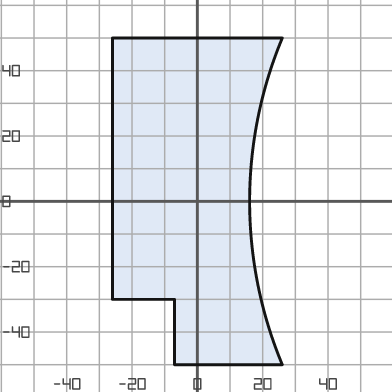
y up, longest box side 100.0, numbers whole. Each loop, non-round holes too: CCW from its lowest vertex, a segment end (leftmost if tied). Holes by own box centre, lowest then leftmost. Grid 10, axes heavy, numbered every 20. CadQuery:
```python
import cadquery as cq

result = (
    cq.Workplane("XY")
    .moveTo(-7.0, -50.0)
    .lineTo(26.0, -50.0)
    .threePointArc((16.0, 0.0), (26.0, 50.0))
    .lineTo(-26.0, 50.0)
    .lineTo(-26.0, -30.0)
    .lineTo(-7.0, -30.0)
    .close()
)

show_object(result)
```